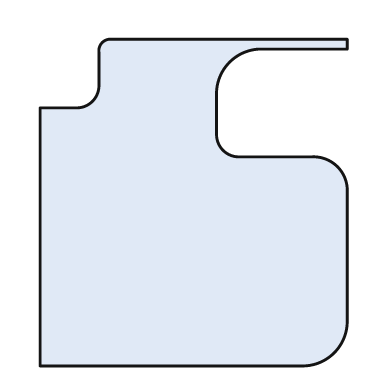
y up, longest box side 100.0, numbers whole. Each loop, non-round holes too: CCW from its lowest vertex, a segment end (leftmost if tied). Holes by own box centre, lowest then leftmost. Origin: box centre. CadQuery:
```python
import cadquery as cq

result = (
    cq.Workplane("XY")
    .moveTo(-47.0, -50.0)
    .lineTo(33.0, -50.0)
    .threePointArc((43.0, -46.0), (47.0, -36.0))
    .lineTo(47.0, 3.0)
    .threePointArc((44.0, 11.0), (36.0, 14.0))
    .lineTo(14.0, 14.0)
    .threePointArc((9.0, 16.0), (7.0, 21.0))
    .lineTo(7.0, 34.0)
    .threePointArc((11.0, 43.0), (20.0, 47.0))
    .lineTo(47.0, 47.0)
    .lineTo(47.0, 50.0)
    .lineTo(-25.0, 50.0)
    .threePointArc((-28.0, 49.0), (-29.0, 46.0))
    .lineTo(-29.0, 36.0)
    .threePointArc((-31.0, 31.0), (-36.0, 29.0))
    .lineTo(-47.0, 29.0)
    .close()
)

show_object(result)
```